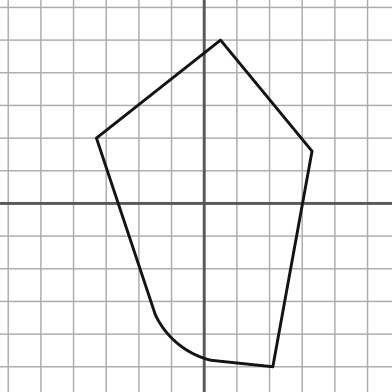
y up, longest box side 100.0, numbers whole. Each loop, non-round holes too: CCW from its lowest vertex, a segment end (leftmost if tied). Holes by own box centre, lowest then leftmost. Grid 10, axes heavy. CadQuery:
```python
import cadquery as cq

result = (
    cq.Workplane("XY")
    .moveTo(21.0, -50.0)
    .lineTo(33.0, 16.0)
    .lineTo(5.0, 50.0)
    .lineTo(-33.0, 20.0)
    .lineTo(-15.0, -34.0)
    .threePointArc((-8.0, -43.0), (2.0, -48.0))
    .close()
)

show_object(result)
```